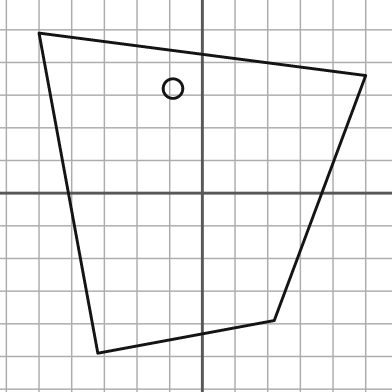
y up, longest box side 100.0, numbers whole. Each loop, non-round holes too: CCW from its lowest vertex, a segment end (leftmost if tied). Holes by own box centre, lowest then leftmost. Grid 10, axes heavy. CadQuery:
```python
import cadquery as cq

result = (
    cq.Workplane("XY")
    .moveTo(-32.0, -49.0)
    .lineTo(22.0, -39.0)
    .lineTo(50.0, 36.0)
    .lineTo(-50.0, 49.0)
    .close()
    .moveTo(-9.0, 32.0)
    .circle(3.0)
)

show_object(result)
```